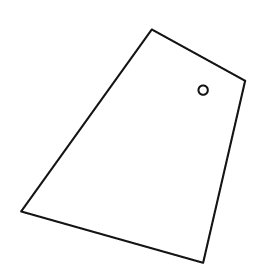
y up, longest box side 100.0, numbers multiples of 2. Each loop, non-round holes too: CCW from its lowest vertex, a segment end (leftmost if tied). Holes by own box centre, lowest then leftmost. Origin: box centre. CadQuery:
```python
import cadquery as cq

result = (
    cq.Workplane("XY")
    .moveTo(30.0, -50.0)
    .lineTo(48.0, 28.0)
    .lineTo(8.0, 50.0)
    .lineTo(-48.0, -28.0)
    .close()
    .moveTo(30.0, 24.0)
    .circle(2.0)
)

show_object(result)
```